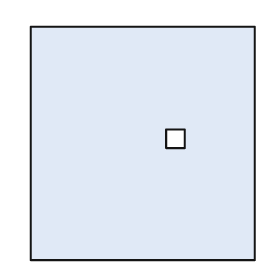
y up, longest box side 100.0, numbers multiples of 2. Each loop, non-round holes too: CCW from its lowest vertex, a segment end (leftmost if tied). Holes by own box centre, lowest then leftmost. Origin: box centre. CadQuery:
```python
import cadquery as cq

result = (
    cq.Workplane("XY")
    .moveTo(-48.0, -50.0)
    .lineTo(48.0, -50.0)
    .lineTo(48.0, 50.0)
    .lineTo(-48.0, 50.0)
    .close()
    .moveTo(10.0, -2.0)
    .lineTo(18.0, -2.0)
    .lineTo(18.0, 6.0)
    .lineTo(10.0, 6.0)
    .close()
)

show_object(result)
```